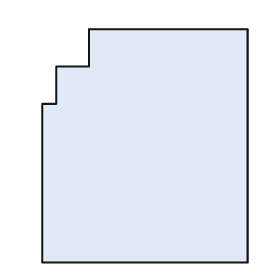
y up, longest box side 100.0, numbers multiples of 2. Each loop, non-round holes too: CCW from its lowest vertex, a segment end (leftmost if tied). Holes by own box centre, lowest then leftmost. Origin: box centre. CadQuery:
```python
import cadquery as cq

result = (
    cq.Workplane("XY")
    .moveTo(-44.0, -50.0)
    .lineTo(44.0, -50.0)
    .lineTo(44.0, 50.0)
    .lineTo(-24.0, 50.0)
    .lineTo(-24.0, 34.0)
    .lineTo(-38.0, 34.0)
    .lineTo(-38.0, 18.0)
    .lineTo(-44.0, 18.0)
    .close()
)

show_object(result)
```